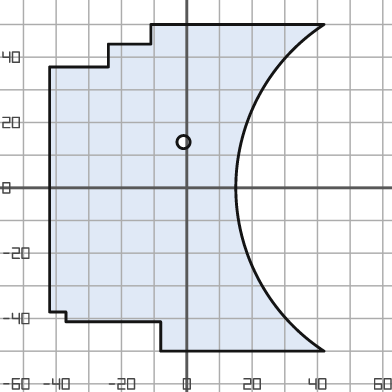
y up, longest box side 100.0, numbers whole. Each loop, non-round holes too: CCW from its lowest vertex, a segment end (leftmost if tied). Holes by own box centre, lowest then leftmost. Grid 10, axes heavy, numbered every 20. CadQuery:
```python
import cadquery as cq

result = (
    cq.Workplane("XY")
    .moveTo(-8.0, -50.0)
    .lineTo(42.0, -50.0)
    .threePointArc((15.0, 0.0), (42.0, 50.0))
    .lineTo(-11.0, 50.0)
    .lineTo(-11.0, 44.0)
    .lineTo(-24.0, 44.0)
    .lineTo(-24.0, 37.0)
    .lineTo(-42.0, 37.0)
    .lineTo(-42.0, -38.0)
    .lineTo(-37.0, -38.0)
    .lineTo(-37.0, -41.0)
    .lineTo(-8.0, -41.0)
    .close()
    .moveTo(-1.0, 14.0)
    .circle(2.0)
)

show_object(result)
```